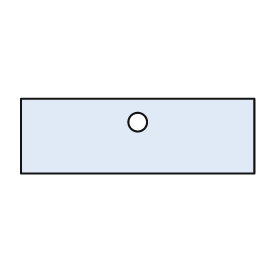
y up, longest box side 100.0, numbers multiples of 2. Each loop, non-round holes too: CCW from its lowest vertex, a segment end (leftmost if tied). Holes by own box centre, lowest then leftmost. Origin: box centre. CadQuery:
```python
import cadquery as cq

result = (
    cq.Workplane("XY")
    .moveTo(-50.0, -16.0)
    .lineTo(50.0, -16.0)
    .lineTo(50.0, 16.0)
    .lineTo(-50.0, 16.0)
    .close()
    .moveTo(0.0, 6.0)
    .circle(4.0)
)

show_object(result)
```